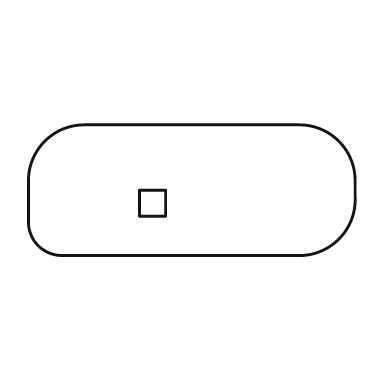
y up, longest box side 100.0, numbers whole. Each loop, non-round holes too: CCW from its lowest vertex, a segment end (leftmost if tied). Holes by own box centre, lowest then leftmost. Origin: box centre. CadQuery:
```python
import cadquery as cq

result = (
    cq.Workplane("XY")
    .moveTo(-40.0, -20.0)
    .lineTo(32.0, -20.0)
    .threePointArc((45.0, -15.0), (50.0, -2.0))
    .lineTo(50.0, 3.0)
    .threePointArc((45.0, 15.0), (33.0, 20.0))
    .lineTo(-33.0, 20.0)
    .threePointArc((-45.0, 15.0), (-50.0, 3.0))
    .lineTo(-50.0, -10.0)
    .threePointArc((-47.0, -17.0), (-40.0, -20.0))
    .close()
    .moveTo(-16.0, -8.0)
    .lineTo(-8.0, -8.0)
    .lineTo(-8.0, 0.0)
    .lineTo(-16.0, 0.0)
    .close()
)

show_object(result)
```